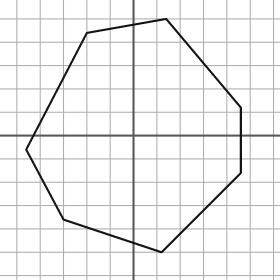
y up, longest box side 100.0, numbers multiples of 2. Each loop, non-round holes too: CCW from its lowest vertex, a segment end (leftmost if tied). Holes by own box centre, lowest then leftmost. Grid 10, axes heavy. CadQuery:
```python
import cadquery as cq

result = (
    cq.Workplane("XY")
    .moveTo(12.0, -50.0)
    .lineTo(46.0, -16.0)
    .lineTo(46.0, 12.0)
    .lineTo(14.0, 50.0)
    .lineTo(-20.0, 44.0)
    .lineTo(-46.0, -6.0)
    .lineTo(-30.0, -36.0)
    .close()
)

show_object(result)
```